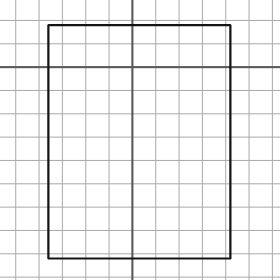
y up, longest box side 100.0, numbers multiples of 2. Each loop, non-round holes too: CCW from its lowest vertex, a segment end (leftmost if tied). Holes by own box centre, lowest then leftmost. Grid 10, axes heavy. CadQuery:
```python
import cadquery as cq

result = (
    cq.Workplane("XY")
    .moveTo(-36.0, -82.0)
    .lineTo(42.0, -82.0)
    .lineTo(42.0, 18.0)
    .lineTo(-36.0, 18.0)
    .close()
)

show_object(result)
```